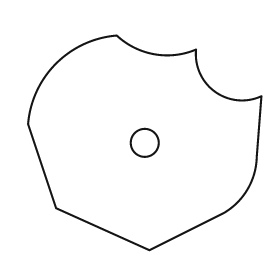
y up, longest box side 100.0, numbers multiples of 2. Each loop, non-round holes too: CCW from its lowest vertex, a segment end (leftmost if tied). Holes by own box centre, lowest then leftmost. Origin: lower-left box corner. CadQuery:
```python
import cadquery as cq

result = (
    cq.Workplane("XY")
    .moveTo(52.0, 0.0)
    .lineTo(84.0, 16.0)
    .threePointArc((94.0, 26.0), (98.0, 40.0))
    .lineTo(100.0, 66.0)
    .threePointArc((80.0, 68.0), (72.0, 86.0))
    .threePointArc((54.0, 84.0), (38.0, 92.0))
    .threePointArc((12.0, 80.0), (0.0, 54.0))
    .lineTo(12.0, 18.0)
    .close()
    .moveTo(50.0, 46.0)
    .circle(6.0)
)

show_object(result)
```